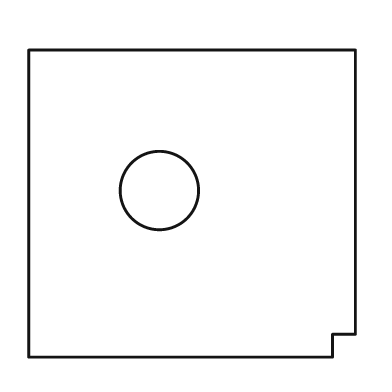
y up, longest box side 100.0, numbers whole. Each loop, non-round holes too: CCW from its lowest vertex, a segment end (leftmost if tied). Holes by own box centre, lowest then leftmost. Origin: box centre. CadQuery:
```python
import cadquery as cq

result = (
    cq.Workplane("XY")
    .moveTo(-50.0, -47.0)
    .lineTo(43.0, -47.0)
    .lineTo(43.0, -40.0)
    .lineTo(50.0, -40.0)
    .lineTo(50.0, 47.0)
    .lineTo(-50.0, 47.0)
    .close()
    .moveTo(-10.0, 4.0)
    .circle(12.0)
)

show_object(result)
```